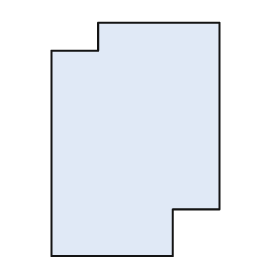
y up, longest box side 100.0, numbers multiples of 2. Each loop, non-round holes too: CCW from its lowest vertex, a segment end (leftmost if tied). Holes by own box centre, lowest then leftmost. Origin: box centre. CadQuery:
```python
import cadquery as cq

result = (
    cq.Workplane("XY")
    .moveTo(-36.0, -50.0)
    .lineTo(16.0, -50.0)
    .lineTo(16.0, -30.0)
    .lineTo(36.0, -30.0)
    .lineTo(36.0, 50.0)
    .lineTo(-16.0, 50.0)
    .lineTo(-16.0, 38.0)
    .lineTo(-36.0, 38.0)
    .close()
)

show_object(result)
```